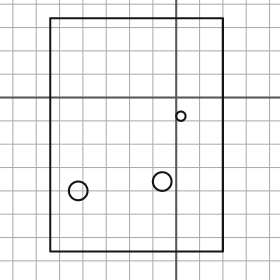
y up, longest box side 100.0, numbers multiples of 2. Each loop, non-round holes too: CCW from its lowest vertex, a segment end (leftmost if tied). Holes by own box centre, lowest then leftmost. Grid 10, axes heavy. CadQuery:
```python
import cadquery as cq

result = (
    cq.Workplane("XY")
    .moveTo(-54.0, -66.0)
    .lineTo(20.0, -66.0)
    .lineTo(20.0, 34.0)
    .lineTo(-54.0, 34.0)
    .close()
    .moveTo(-42.0, -40.0)
    .circle(4.0)
    .moveTo(-6.0, -36.0)
    .circle(4.0)
    .moveTo(2.0, -8.0)
    .circle(2.0)
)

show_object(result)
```